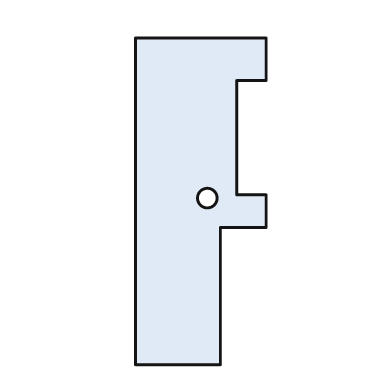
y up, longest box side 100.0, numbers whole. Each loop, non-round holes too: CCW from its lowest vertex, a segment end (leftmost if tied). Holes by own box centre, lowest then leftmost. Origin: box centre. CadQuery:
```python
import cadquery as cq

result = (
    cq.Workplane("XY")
    .moveTo(-20.0, -50.0)
    .lineTo(6.0, -50.0)
    .lineTo(6.0, -8.0)
    .lineTo(20.0, -8.0)
    .lineTo(20.0, 2.0)
    .lineTo(11.0, 2.0)
    .lineTo(11.0, 37.0)
    .lineTo(20.0, 37.0)
    .lineTo(20.0, 50.0)
    .lineTo(-20.0, 50.0)
    .close()
    .moveTo(2.0, 1.0)
    .circle(3.0)
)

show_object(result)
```